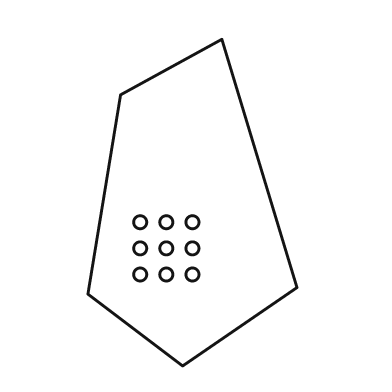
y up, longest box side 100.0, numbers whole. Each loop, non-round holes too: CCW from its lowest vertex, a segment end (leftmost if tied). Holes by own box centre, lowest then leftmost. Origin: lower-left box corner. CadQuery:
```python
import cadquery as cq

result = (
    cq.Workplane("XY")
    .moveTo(29.0, 0.0)
    .lineTo(64.0, 24.0)
    .lineTo(41.0, 100.0)
    .lineTo(10.0, 83.0)
    .lineTo(0.0, 22.0)
    .close()
    .moveTo(16.0, 28.0)
    .circle(2.0)
    .moveTo(24.0, 28.0)
    .circle(2.0)
    .moveTo(32.0, 28.0)
    .circle(2.0)
    .moveTo(16.0, 36.0)
    .circle(2.0)
    .moveTo(24.0, 36.0)
    .circle(2.0)
    .moveTo(32.0, 36.0)
    .circle(2.0)
    .moveTo(16.0, 44.0)
    .circle(2.0)
    .moveTo(24.0, 44.0)
    .circle(2.0)
    .moveTo(32.0, 44.0)
    .circle(2.0)
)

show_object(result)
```